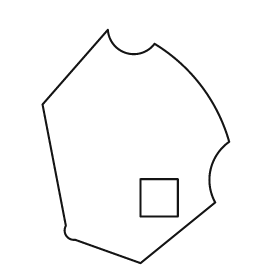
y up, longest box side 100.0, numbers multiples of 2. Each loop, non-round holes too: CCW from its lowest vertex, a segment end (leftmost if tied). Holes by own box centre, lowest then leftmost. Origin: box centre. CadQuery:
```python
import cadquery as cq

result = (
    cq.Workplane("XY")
    .moveTo(2.0, -50.0)
    .lineTo(34.0, -24.0)
    .threePointArc((32.0, -10.0), (40.0, 2.0))
    .threePointArc((28.0, 26.0), (8.0, 44.0))
    .threePointArc((-4.0, 40.0), (-12.0, 50.0))
    .lineTo(-40.0, 18.0)
    .lineTo(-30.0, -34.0)
    .threePointArc((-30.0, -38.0), (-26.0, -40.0))
    .close()
    .moveTo(2.0, -30.0)
    .lineTo(18.0, -30.0)
    .lineTo(18.0, -14.0)
    .lineTo(2.0, -14.0)
    .close()
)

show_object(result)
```